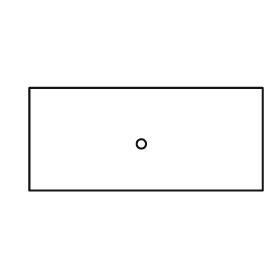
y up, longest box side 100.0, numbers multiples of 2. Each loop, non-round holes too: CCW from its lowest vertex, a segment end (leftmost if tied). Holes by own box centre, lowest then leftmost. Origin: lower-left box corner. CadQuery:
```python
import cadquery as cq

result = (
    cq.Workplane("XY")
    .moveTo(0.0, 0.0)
    .lineTo(100.0, 0.0)
    .lineTo(100.0, 44.0)
    .lineTo(0.0, 44.0)
    .close()
    .moveTo(48.0, 20.0)
    .circle(2.0)
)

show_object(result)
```